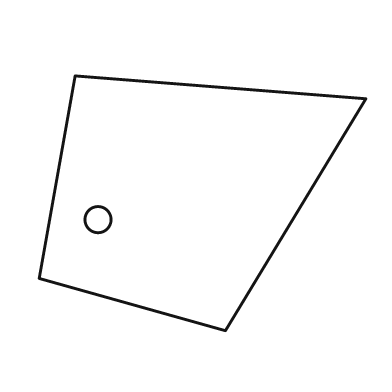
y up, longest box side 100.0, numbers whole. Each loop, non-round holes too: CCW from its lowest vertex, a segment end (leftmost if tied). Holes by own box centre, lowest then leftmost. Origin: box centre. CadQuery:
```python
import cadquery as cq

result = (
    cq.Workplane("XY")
    .moveTo(7.0, -39.0)
    .lineTo(50.0, 32.0)
    .lineTo(-39.0, 39.0)
    .lineTo(-50.0, -23.0)
    .close()
    .moveTo(-32.0, -5.0)
    .circle(4.0)
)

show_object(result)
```